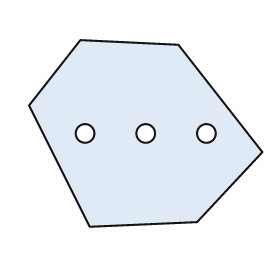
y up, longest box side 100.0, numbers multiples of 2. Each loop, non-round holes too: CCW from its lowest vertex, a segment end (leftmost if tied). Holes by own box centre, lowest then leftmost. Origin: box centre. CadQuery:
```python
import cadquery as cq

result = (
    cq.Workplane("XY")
    .moveTo(-24.0, -40.0)
    .lineTo(22.0, -38.0)
    .lineTo(50.0, -8.0)
    .lineTo(14.0, 38.0)
    .lineTo(-28.0, 40.0)
    .lineTo(-50.0, 12.0)
    .close()
    .moveTo(-26.0, 0.0)
    .circle(4.0)
    .moveTo(0.0, 0.0)
    .circle(4.0)
    .moveTo(26.0, 0.0)
    .circle(4.0)
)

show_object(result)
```